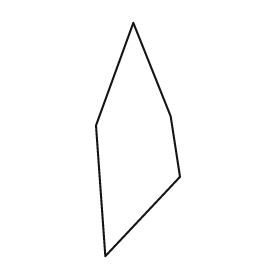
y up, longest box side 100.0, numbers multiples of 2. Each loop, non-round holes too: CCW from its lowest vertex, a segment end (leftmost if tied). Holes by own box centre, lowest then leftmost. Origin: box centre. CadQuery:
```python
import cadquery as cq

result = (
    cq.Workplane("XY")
    .moveTo(-14.0, -50.0)
    .lineTo(18.0, -16.0)
    .lineTo(14.0, 10.0)
    .lineTo(-2.0, 50.0)
    .lineTo(-18.0, 6.0)
    .close()
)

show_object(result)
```